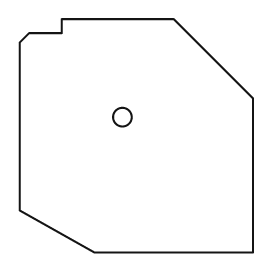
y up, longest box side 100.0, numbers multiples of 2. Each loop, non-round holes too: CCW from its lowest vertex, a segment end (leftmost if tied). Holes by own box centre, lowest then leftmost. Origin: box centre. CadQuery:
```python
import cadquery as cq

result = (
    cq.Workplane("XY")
    .moveTo(-18.0, -50.0)
    .lineTo(50.0, -50.0)
    .lineTo(50.0, 16.0)
    .lineTo(16.0, 50.0)
    .lineTo(-32.0, 50.0)
    .lineTo(-32.0, 44.0)
    .lineTo(-46.0, 44.0)
    .lineTo(-50.0, 40.0)
    .lineTo(-50.0, -32.0)
    .close()
    .moveTo(-6.0, 8.0)
    .circle(4.0)
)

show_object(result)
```